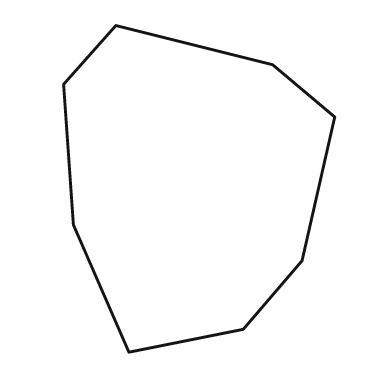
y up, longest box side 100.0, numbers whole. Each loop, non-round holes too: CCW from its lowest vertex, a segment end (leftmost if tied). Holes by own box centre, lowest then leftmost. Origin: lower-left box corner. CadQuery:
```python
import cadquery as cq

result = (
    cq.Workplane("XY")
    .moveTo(20.0, 0.0)
    .lineTo(55.0, 7.0)
    .lineTo(73.0, 28.0)
    .lineTo(83.0, 72.0)
    .lineTo(64.0, 88.0)
    .lineTo(16.0, 100.0)
    .lineTo(0.0, 82.0)
    .lineTo(3.0, 39.0)
    .close()
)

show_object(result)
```